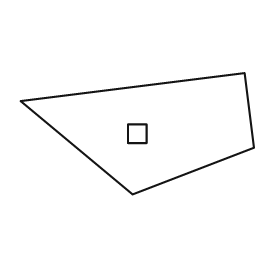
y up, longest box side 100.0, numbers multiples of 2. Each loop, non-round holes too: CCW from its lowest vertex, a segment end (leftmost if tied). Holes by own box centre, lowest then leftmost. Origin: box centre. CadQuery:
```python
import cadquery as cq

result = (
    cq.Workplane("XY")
    .moveTo(-2.0, -26.0)
    .lineTo(50.0, -6.0)
    .lineTo(46.0, 26.0)
    .lineTo(-50.0, 14.0)
    .close()
    .moveTo(-4.0, -4.0)
    .lineTo(4.0, -4.0)
    .lineTo(4.0, 4.0)
    .lineTo(-4.0, 4.0)
    .close()
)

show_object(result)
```